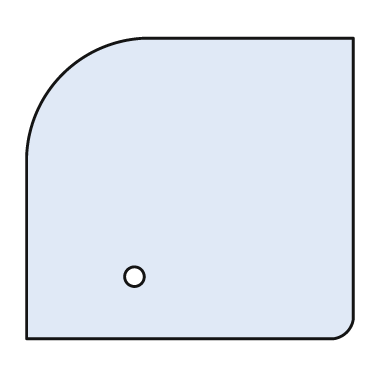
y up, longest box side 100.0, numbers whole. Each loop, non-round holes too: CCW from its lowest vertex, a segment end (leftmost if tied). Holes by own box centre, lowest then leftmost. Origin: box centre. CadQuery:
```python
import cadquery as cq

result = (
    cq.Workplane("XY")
    .moveTo(-50.0, -46.0)
    .lineTo(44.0, -46.0)
    .threePointArc((48.0, -44.0), (50.0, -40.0))
    .lineTo(50.0, 46.0)
    .lineTo(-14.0, 46.0)
    .threePointArc((-39.0, 35.0), (-50.0, 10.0))
    .close()
    .moveTo(-17.0, -27.0)
    .circle(3.0)
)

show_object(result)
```